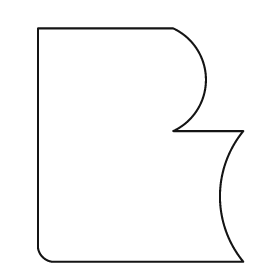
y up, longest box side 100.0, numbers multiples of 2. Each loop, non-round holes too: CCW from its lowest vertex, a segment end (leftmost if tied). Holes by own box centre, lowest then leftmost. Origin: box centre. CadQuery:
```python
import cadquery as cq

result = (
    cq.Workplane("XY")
    .moveTo(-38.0, -50.0)
    .lineTo(44.0, -50.0)
    .threePointArc((34.0, -22.0), (44.0, 6.0))
    .lineTo(14.0, 6.0)
    .threePointArc((28.0, 28.0), (14.0, 50.0))
    .lineTo(-44.0, 50.0)
    .lineTo(-44.0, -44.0)
    .threePointArc((-42.0, -48.0), (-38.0, -50.0))
    .close()
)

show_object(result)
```